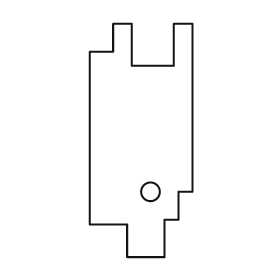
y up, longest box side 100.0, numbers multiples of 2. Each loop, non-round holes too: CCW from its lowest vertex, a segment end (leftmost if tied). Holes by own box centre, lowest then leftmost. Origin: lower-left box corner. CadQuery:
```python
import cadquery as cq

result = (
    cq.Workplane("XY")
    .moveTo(16.0, 0.0)
    .lineTo(32.0, 0.0)
    .lineTo(32.0, 16.0)
    .lineTo(38.0, 16.0)
    .lineTo(38.0, 28.0)
    .lineTo(44.0, 28.0)
    .lineTo(44.0, 100.0)
    .lineTo(36.0, 100.0)
    .lineTo(36.0, 82.0)
    .lineTo(18.0, 82.0)
    .lineTo(18.0, 100.0)
    .lineTo(10.0, 100.0)
    .lineTo(10.0, 88.0)
    .lineTo(0.0, 88.0)
    .lineTo(0.0, 14.0)
    .lineTo(16.0, 14.0)
    .close()
    .moveTo(26.0, 28.0)
    .circle(4.0)
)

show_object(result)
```